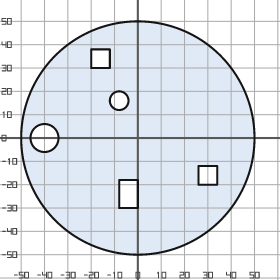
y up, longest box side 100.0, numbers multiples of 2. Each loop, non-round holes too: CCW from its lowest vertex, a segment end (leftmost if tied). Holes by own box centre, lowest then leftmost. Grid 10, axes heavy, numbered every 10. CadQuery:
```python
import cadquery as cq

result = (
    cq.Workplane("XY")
    .moveTo(0.0, 0.0)
    .circle(50.0)
    .moveTo(-8.0, -30.0)
    .lineTo(0.0, -30.0)
    .lineTo(0.0, -18.0)
    .lineTo(-8.0, -18.0)
    .close()
    .moveTo(26.0, -20.0)
    .lineTo(34.0, -20.0)
    .lineTo(34.0, -12.0)
    .lineTo(26.0, -12.0)
    .close()
    .moveTo(-40.0, 0.0)
    .circle(6.0)
    .moveTo(-8.0, 16.0)
    .circle(4.0)
    .moveTo(-20.0, 30.0)
    .lineTo(-12.0, 30.0)
    .lineTo(-12.0, 38.0)
    .lineTo(-20.0, 38.0)
    .close()
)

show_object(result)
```